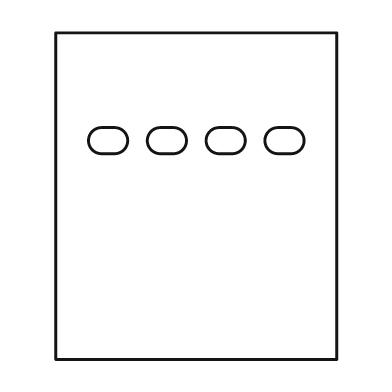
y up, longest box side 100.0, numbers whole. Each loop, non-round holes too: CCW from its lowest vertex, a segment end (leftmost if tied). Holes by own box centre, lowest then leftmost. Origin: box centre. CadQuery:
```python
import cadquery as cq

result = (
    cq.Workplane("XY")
    .moveTo(-43.0, -50.0)
    .lineTo(43.0, -50.0)
    .lineTo(43.0, 50.0)
    .lineTo(-43.0, 50.0)
    .close()
    .moveTo(-29.0, 13.0)
    .lineTo(-25.0, 13.0)
    .threePointArc((-21.0, 17.0), (-25.0, 21.0))
    .lineTo(-29.0, 21.0)
    .threePointArc((-33.0, 17.0), (-29.0, 13.0))
    .close()
    .moveTo(-11.0, 13.0)
    .lineTo(-7.0, 13.0)
    .threePointArc((-3.0, 17.0), (-7.0, 21.0))
    .lineTo(-11.0, 21.0)
    .threePointArc((-15.0, 17.0), (-11.0, 13.0))
    .close()
    .moveTo(7.0, 13.0)
    .lineTo(11.0, 13.0)
    .threePointArc((15.0, 17.0), (11.0, 21.0))
    .lineTo(7.0, 21.0)
    .threePointArc((3.0, 17.0), (7.0, 13.0))
    .close()
    .moveTo(25.0, 13.0)
    .lineTo(29.0, 13.0)
    .threePointArc((33.0, 17.0), (29.0, 21.0))
    .lineTo(25.0, 21.0)
    .threePointArc((21.0, 17.0), (25.0, 13.0))
    .close()
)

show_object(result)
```